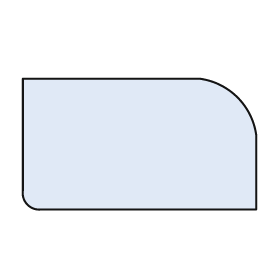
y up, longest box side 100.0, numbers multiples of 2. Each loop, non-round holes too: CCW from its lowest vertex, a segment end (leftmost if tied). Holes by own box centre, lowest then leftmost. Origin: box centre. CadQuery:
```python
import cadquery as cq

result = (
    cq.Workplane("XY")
    .moveTo(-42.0, -28.0)
    .lineTo(50.0, -28.0)
    .lineTo(50.0, 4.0)
    .threePointArc((42.0, 20.0), (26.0, 28.0))
    .lineTo(-50.0, 28.0)
    .lineTo(-50.0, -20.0)
    .threePointArc((-48.0, -26.0), (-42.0, -28.0))
    .close()
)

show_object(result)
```